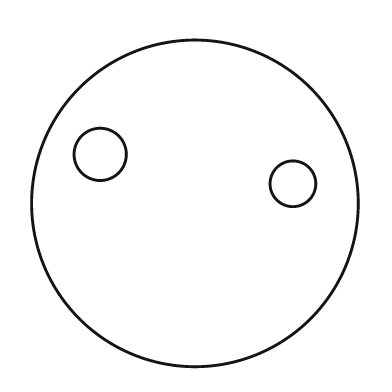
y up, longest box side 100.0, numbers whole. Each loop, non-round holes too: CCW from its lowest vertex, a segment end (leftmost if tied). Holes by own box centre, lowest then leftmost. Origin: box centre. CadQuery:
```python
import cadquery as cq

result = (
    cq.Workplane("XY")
    .moveTo(0.0, 0.0)
    .circle(50.0)
    .moveTo(30.0, 6.0)
    .circle(7.0)
    .moveTo(-29.0, 15.0)
    .circle(8.0)
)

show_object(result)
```